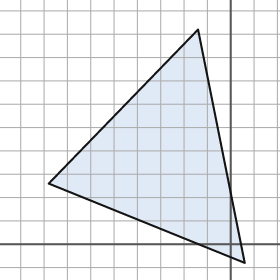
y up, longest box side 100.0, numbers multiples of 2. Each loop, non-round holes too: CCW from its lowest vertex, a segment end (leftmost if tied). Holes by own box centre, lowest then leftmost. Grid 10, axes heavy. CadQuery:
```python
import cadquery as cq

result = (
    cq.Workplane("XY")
    .moveTo(6.0, -8.0)
    .lineTo(-14.0, 92.0)
    .lineTo(-78.0, 26.0)
    .close()
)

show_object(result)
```